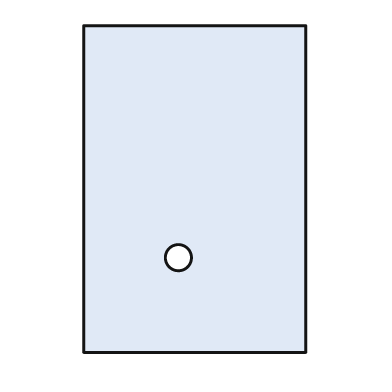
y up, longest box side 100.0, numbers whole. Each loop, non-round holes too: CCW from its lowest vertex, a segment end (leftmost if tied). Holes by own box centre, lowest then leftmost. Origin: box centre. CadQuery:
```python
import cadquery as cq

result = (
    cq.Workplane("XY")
    .moveTo(-34.0, -50.0)
    .lineTo(34.0, -50.0)
    .lineTo(34.0, 50.0)
    .lineTo(-34.0, 50.0)
    .close()
    .moveTo(-5.0, -21.0)
    .circle(4.0)
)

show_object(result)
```